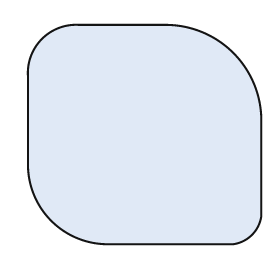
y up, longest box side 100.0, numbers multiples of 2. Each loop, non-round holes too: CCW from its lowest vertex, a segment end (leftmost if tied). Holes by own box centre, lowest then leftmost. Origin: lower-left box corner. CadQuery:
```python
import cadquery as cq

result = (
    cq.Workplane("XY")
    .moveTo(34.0, 0.0)
    .lineTo(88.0, 0.0)
    .threePointArc((96.0, 4.0), (100.0, 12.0))
    .lineTo(100.0, 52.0)
    .threePointArc((88.0, 82.0), (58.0, 94.0))
    .lineTo(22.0, 94.0)
    .threePointArc((6.0, 88.0), (0.0, 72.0))
    .lineTo(0.0, 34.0)
    .threePointArc((10.0, 10.0), (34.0, 0.0))
    .close()
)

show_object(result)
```